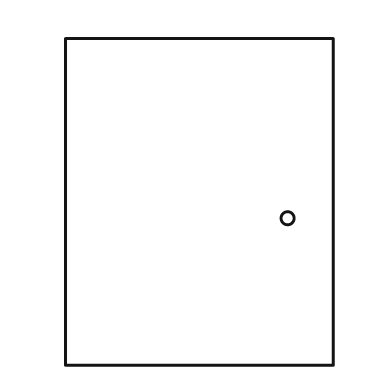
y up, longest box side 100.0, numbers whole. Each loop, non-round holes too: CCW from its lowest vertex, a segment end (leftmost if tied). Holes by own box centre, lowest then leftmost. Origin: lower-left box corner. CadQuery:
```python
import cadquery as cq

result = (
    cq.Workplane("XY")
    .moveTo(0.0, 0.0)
    .lineTo(82.0, 0.0)
    .lineTo(82.0, 100.0)
    .lineTo(0.0, 100.0)
    .close()
    .moveTo(68.0, 45.0)
    .circle(2.0)
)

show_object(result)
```